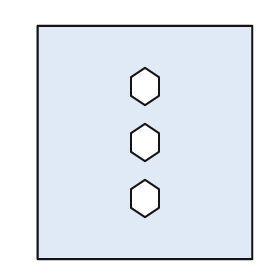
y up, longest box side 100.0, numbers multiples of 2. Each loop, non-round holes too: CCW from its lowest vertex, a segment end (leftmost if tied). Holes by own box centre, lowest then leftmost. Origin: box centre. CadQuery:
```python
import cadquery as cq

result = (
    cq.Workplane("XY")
    .moveTo(-46.0, -50.0)
    .lineTo(46.0, -50.0)
    .lineTo(46.0, 50.0)
    .lineTo(-46.0, 50.0)
    .close()
    .moveTo(0.0, -32.0)
    .lineTo(6.0, -28.0)
    .lineTo(6.0, -20.0)
    .lineTo(0.0, -16.0)
    .lineTo(-6.0, -20.0)
    .lineTo(-6.0, -28.0)
    .close()
    .moveTo(0.0, -8.0)
    .lineTo(6.0, -4.0)
    .lineTo(6.0, 4.0)
    .lineTo(0.0, 8.0)
    .lineTo(-6.0, 4.0)
    .lineTo(-6.0, -4.0)
    .close()
    .moveTo(0.0, 16.0)
    .lineTo(6.0, 20.0)
    .lineTo(6.0, 28.0)
    .lineTo(0.0, 32.0)
    .lineTo(-6.0, 28.0)
    .lineTo(-6.0, 20.0)
    .close()
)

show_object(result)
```